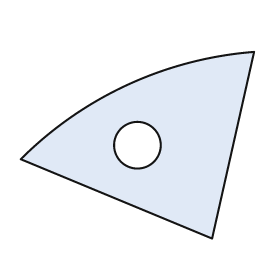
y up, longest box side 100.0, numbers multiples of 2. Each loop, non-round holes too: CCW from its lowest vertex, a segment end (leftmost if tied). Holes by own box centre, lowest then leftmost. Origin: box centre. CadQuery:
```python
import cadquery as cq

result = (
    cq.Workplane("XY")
    .moveTo(32.0, -40.0)
    .lineTo(50.0, 40.0)
    .threePointArc((-4.0, 26.0), (-50.0, -6.0))
    .close()
    .moveTo(0.0, 0.0)
    .circle(10.0)
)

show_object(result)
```